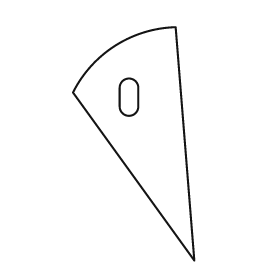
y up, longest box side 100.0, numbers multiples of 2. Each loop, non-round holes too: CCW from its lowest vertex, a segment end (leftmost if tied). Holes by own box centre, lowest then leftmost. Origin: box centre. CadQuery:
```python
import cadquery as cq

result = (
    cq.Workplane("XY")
    .moveTo(26.0, -50.0)
    .lineTo(18.0, 50.0)
    .threePointArc((-8.0, 42.0), (-26.0, 22.0))
    .close()
    .moveTo(-6.0, 16.0)
    .threePointArc((-2.0, 12.0), (2.0, 16.0))
    .lineTo(2.0, 24.0)
    .threePointArc((-2.0, 28.0), (-6.0, 24.0))
    .close()
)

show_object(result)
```